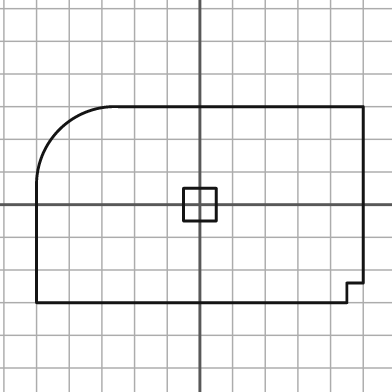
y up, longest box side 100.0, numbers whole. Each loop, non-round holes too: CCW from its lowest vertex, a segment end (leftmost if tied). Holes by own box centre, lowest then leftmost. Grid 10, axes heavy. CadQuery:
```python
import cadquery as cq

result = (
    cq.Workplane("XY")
    .moveTo(-50.0, -30.0)
    .lineTo(45.0, -30.0)
    .lineTo(45.0, -24.0)
    .lineTo(50.0, -24.0)
    .lineTo(50.0, 30.0)
    .lineTo(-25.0, 30.0)
    .threePointArc((-43.0, 23.0), (-50.0, 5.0))
    .close()
    .moveTo(-5.0, -5.0)
    .lineTo(5.0, -5.0)
    .lineTo(5.0, 5.0)
    .lineTo(-5.0, 5.0)
    .close()
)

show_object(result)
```